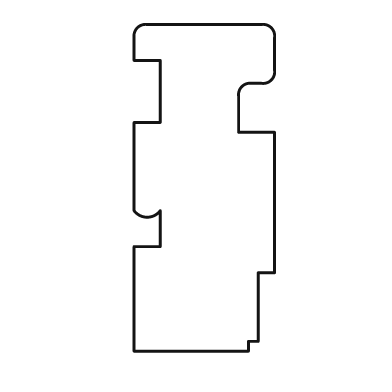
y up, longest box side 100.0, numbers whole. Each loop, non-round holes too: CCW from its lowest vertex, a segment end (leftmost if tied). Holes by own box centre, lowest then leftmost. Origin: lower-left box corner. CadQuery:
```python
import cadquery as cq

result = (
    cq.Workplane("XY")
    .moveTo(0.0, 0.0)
    .lineTo(35.0, 0.0)
    .lineTo(35.0, 3.0)
    .lineTo(38.0, 3.0)
    .lineTo(38.0, 24.0)
    .lineTo(43.0, 24.0)
    .lineTo(43.0, 67.0)
    .lineTo(32.0, 67.0)
    .lineTo(32.0, 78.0)
    .threePointArc((33.0, 81.0), (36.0, 82.0))
    .lineTo(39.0, 82.0)
    .threePointArc((42.0, 83.0), (43.0, 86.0))
    .lineTo(43.0, 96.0)
    .threePointArc((42.0, 99.0), (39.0, 100.0))
    .lineTo(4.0, 100.0)
    .threePointArc((1.0, 99.0), (0.0, 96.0))
    .lineTo(0.0, 89.0)
    .lineTo(8.0, 89.0)
    .lineTo(8.0, 70.0)
    .lineTo(0.0, 70.0)
    .lineTo(0.0, 43.0)
    .threePointArc((4.0, 41.0), (8.0, 43.0))
    .lineTo(8.0, 32.0)
    .lineTo(0.0, 32.0)
    .close()
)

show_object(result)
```